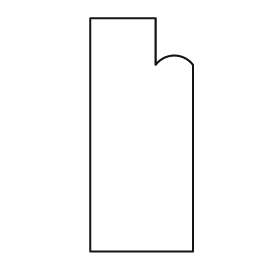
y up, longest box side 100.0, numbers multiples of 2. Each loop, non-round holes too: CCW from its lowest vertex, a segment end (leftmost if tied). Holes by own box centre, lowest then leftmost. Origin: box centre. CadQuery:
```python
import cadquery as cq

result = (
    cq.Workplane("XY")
    .moveTo(-22.0, -50.0)
    .lineTo(22.0, -50.0)
    .lineTo(22.0, 30.0)
    .threePointArc((14.0, 34.0), (6.0, 30.0))
    .lineTo(6.0, 50.0)
    .lineTo(-22.0, 50.0)
    .close()
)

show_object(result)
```